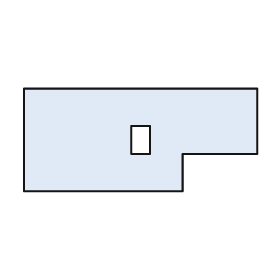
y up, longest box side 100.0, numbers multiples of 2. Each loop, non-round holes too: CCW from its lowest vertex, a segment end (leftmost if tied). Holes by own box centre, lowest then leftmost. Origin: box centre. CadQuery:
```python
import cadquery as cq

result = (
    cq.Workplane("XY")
    .moveTo(-50.0, -22.0)
    .lineTo(18.0, -22.0)
    .lineTo(18.0, -6.0)
    .lineTo(50.0, -6.0)
    .lineTo(50.0, 22.0)
    .lineTo(-50.0, 22.0)
    .close()
    .moveTo(-4.0, -6.0)
    .lineTo(4.0, -6.0)
    .lineTo(4.0, 6.0)
    .lineTo(-4.0, 6.0)
    .close()
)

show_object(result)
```